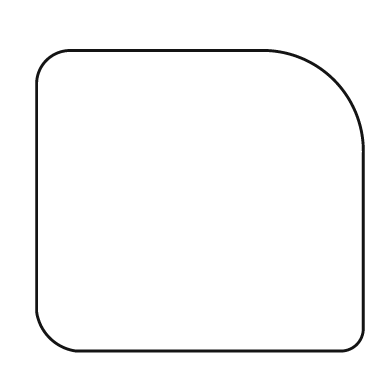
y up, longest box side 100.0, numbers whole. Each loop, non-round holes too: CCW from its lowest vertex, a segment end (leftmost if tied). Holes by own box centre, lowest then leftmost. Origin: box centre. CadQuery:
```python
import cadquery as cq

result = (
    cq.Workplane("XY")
    .moveTo(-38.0, -46.0)
    .lineTo(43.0, -46.0)
    .threePointArc((48.0, -44.0), (50.0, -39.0))
    .lineTo(50.0, 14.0)
    .threePointArc((41.0, 37.0), (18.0, 46.0))
    .lineTo(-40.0, 46.0)
    .threePointArc((-47.0, 43.0), (-50.0, 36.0))
    .lineTo(-50.0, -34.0)
    .threePointArc((-46.0, -42.0), (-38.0, -46.0))
    .close()
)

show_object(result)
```